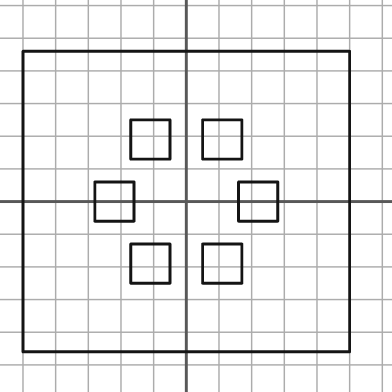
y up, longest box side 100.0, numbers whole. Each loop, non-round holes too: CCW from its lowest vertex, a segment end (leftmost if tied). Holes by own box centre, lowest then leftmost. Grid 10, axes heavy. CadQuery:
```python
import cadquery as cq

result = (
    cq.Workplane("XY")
    .moveTo(-50.0, -46.0)
    .lineTo(50.0, -46.0)
    .lineTo(50.0, 46.0)
    .lineTo(-50.0, 46.0)
    .close()
    .moveTo(-17.0, -25.0)
    .lineTo(-5.0, -25.0)
    .lineTo(-5.0, -13.0)
    .lineTo(-17.0, -13.0)
    .close()
    .moveTo(5.0, -25.0)
    .lineTo(17.0, -25.0)
    .lineTo(17.0, -13.0)
    .lineTo(5.0, -13.0)
    .close()
    .moveTo(-28.0, -6.0)
    .lineTo(-16.0, -6.0)
    .lineTo(-16.0, 6.0)
    .lineTo(-28.0, 6.0)
    .close()
    .moveTo(16.0, -6.0)
    .lineTo(28.0, -6.0)
    .lineTo(28.0, 6.0)
    .lineTo(16.0, 6.0)
    .close()
    .moveTo(-17.0, 13.0)
    .lineTo(-5.0, 13.0)
    .lineTo(-5.0, 25.0)
    .lineTo(-17.0, 25.0)
    .close()
    .moveTo(5.0, 13.0)
    .lineTo(17.0, 13.0)
    .lineTo(17.0, 25.0)
    .lineTo(5.0, 25.0)
    .close()
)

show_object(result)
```